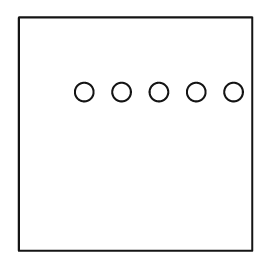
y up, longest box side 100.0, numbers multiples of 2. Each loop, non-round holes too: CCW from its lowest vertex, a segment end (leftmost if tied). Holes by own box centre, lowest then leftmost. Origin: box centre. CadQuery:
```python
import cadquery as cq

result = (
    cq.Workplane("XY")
    .moveTo(-50.0, -50.0)
    .lineTo(50.0, -50.0)
    .lineTo(50.0, 50.0)
    .lineTo(-50.0, 50.0)
    .close()
    .moveTo(-22.0, 18.0)
    .circle(4.0)
    .moveTo(-6.0, 18.0)
    .circle(4.0)
    .moveTo(10.0, 18.0)
    .circle(4.0)
    .moveTo(26.0, 18.0)
    .circle(4.0)
    .moveTo(42.0, 18.0)
    .circle(4.0)
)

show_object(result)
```